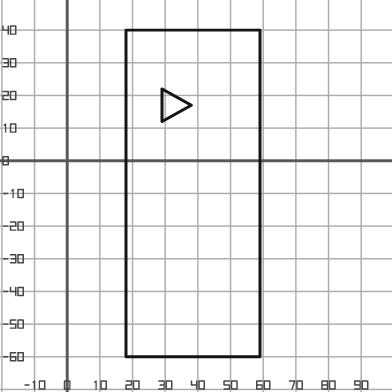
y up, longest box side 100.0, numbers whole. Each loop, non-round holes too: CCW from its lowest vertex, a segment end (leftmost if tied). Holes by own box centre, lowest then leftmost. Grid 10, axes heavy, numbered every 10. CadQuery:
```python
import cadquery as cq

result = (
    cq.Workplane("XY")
    .moveTo(18.0, -60.0)
    .lineTo(59.0, -60.0)
    .lineTo(59.0, 40.0)
    .lineTo(18.0, 40.0)
    .close()
    .moveTo(29.0, 12.0)
    .lineTo(38.0, 17.0)
    .lineTo(29.0, 22.0)
    .close()
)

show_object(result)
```